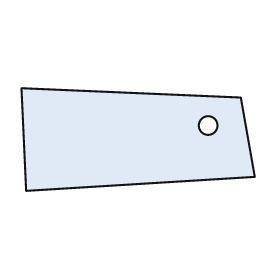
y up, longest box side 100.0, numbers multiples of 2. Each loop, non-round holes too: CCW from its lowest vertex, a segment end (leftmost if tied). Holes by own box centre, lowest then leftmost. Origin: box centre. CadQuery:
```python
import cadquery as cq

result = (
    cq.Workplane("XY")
    .moveTo(-48.0, -22.0)
    .lineTo(50.0, -16.0)
    .lineTo(44.0, 18.0)
    .lineTo(-50.0, 22.0)
    .close()
    .moveTo(30.0, 6.0)
    .circle(4.0)
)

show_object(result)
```